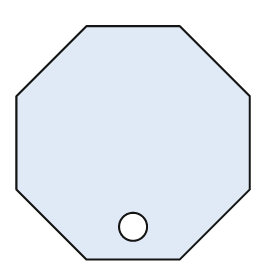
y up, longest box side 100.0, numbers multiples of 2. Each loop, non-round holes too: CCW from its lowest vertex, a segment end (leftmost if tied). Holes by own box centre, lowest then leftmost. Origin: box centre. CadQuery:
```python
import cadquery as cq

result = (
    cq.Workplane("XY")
    .moveTo(-20.0, -50.0)
    .lineTo(20.0, -50.0)
    .lineTo(50.0, -20.0)
    .lineTo(50.0, 20.0)
    .lineTo(20.0, 50.0)
    .lineTo(-20.0, 50.0)
    .lineTo(-50.0, 20.0)
    .lineTo(-50.0, -20.0)
    .close()
    .moveTo(0.0, -36.0)
    .circle(6.0)
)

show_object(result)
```